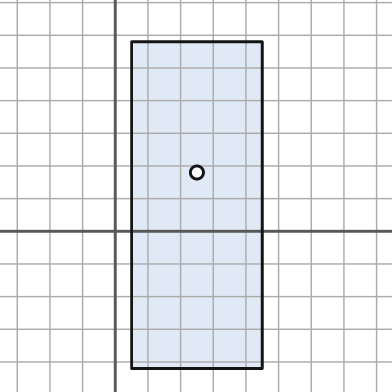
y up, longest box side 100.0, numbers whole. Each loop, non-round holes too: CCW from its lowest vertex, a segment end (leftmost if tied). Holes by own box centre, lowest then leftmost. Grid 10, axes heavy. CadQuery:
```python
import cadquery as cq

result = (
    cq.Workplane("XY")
    .moveTo(5.0, -42.0)
    .lineTo(45.0, -42.0)
    .lineTo(45.0, 58.0)
    .lineTo(5.0, 58.0)
    .close()
    .moveTo(25.0, 18.0)
    .circle(2.0)
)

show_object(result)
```